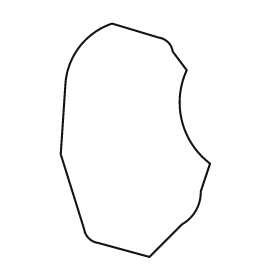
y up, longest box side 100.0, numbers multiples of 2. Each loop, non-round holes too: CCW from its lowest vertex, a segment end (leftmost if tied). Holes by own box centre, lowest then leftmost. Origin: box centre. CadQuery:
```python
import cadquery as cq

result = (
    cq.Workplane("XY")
    .moveTo(6.0, -50.0)
    .lineTo(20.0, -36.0)
    .threePointArc((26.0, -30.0), (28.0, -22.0))
    .lineTo(32.0, -10.0)
    .threePointArc((20.0, 8.0), (22.0, 30.0))
    .lineTo(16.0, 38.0)
    .threePointArc((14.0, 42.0), (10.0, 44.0))
    .lineTo(-10.0, 50.0)
    .threePointArc((-24.0, 40.0), (-30.0, 24.0))
    .lineTo(-32.0, -6.0)
    .lineTo(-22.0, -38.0)
    .threePointArc((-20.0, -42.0), (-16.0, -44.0))
    .close()
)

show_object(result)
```